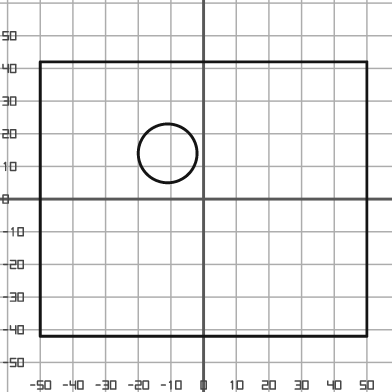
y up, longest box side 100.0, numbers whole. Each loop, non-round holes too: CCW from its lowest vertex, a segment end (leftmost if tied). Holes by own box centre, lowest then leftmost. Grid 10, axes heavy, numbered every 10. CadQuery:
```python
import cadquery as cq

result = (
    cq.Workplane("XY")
    .moveTo(-50.0, -42.0)
    .lineTo(50.0, -42.0)
    .lineTo(50.0, 42.0)
    .lineTo(-50.0, 42.0)
    .close()
    .moveTo(-11.0, 14.0)
    .circle(9.0)
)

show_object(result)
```